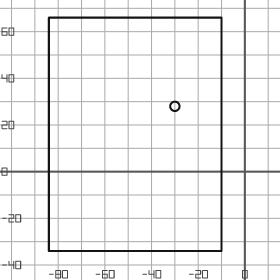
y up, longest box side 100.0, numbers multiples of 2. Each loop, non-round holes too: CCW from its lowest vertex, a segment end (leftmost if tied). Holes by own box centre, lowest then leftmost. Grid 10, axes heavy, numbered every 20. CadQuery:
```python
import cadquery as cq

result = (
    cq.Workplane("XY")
    .moveTo(-84.0, -34.0)
    .lineTo(-10.0, -34.0)
    .lineTo(-10.0, 66.0)
    .lineTo(-84.0, 66.0)
    .close()
    .moveTo(-30.0, 28.0)
    .circle(2.0)
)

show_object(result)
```